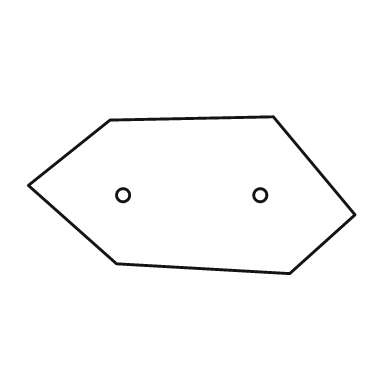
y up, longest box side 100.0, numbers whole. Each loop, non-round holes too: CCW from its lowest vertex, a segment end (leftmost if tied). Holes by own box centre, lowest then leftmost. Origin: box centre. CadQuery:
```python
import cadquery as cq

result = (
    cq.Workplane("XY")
    .moveTo(30.0, -24.0)
    .lineTo(50.0, -6.0)
    .lineTo(25.0, 24.0)
    .lineTo(-25.0, 23.0)
    .lineTo(-50.0, 3.0)
    .lineTo(-23.0, -21.0)
    .close()
    .moveTo(-21.0, 0.0)
    .circle(2.0)
    .moveTo(21.0, 0.0)
    .circle(2.0)
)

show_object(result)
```